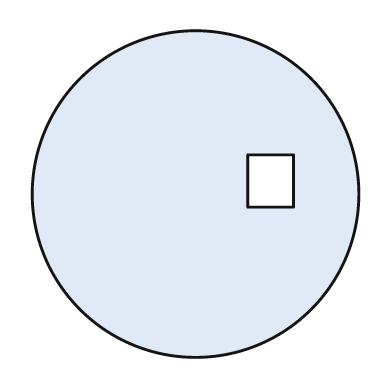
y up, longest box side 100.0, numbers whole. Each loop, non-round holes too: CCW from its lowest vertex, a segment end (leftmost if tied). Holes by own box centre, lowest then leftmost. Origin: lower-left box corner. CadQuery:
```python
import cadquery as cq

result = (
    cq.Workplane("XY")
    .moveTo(50.0, 50.0)
    .circle(50.0)
    .moveTo(66.0, 46.0)
    .lineTo(80.0, 46.0)
    .lineTo(80.0, 62.0)
    .lineTo(66.0, 62.0)
    .close()
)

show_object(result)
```